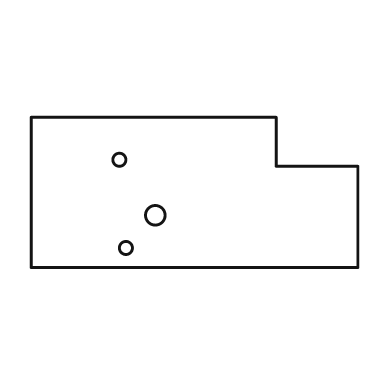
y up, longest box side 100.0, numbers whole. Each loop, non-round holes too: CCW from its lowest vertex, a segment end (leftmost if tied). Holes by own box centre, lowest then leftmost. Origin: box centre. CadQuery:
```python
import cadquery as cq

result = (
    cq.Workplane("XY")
    .moveTo(-50.0, -23.0)
    .lineTo(50.0, -23.0)
    .lineTo(50.0, 8.0)
    .lineTo(25.0, 8.0)
    .lineTo(25.0, 23.0)
    .lineTo(-50.0, 23.0)
    .close()
    .moveTo(-21.0, -17.0)
    .circle(2.0)
    .moveTo(-12.0, -7.0)
    .circle(3.0)
    .moveTo(-23.0, 10.0)
    .circle(2.0)
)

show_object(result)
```